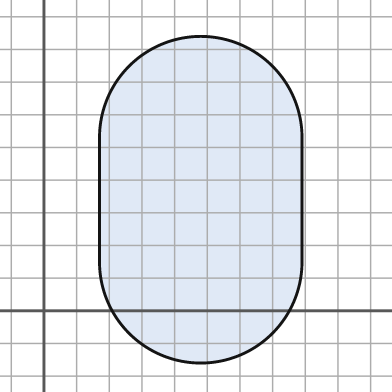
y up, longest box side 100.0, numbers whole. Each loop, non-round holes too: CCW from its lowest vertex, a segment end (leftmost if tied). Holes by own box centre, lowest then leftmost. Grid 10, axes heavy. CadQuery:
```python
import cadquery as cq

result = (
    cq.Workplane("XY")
    .moveTo(17.0, 15.0)
    .threePointArc((48.0, -16.0), (79.0, 15.0))
    .lineTo(79.0, 53.0)
    .threePointArc((48.0, 84.0), (17.0, 53.0))
    .close()
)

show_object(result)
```